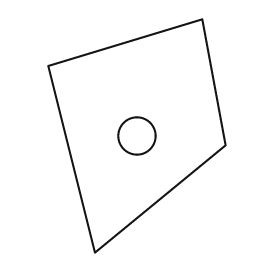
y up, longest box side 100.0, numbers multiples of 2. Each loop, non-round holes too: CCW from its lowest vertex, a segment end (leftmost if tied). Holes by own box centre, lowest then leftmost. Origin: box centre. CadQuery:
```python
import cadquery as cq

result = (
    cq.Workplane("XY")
    .moveTo(-18.0, -50.0)
    .lineTo(38.0, -4.0)
    .lineTo(28.0, 50.0)
    .lineTo(-38.0, 30.0)
    .close()
    .moveTo(0.0, 0.0)
    .circle(8.0)
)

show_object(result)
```